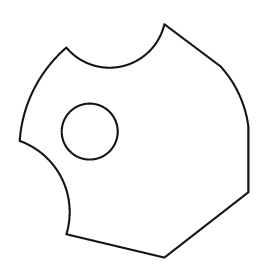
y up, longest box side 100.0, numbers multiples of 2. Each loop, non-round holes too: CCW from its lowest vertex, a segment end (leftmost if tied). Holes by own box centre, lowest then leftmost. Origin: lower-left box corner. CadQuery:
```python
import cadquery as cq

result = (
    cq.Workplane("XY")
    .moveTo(62.0, 0.0)
    .lineTo(98.0, 28.0)
    .lineTo(98.0, 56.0)
    .threePointArc((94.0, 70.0), (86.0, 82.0))
    .lineTo(62.0, 100.0)
    .threePointArc((44.0, 82.0), (20.0, 90.0))
    .threePointArc((6.0, 72.0), (0.0, 50.0))
    .threePointArc((18.0, 34.0), (20.0, 10.0))
    .close()
    .moveTo(30.0, 54.0)
    .circle(12.0)
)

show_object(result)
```